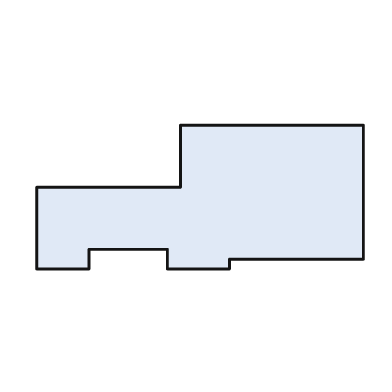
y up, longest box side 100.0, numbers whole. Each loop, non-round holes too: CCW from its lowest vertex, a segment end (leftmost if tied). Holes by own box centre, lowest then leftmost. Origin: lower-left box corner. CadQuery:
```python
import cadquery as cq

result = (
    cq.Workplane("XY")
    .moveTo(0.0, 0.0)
    .lineTo(16.0, 0.0)
    .lineTo(16.0, 6.0)
    .lineTo(40.0, 6.0)
    .lineTo(40.0, 0.0)
    .lineTo(59.0, 0.0)
    .lineTo(59.0, 3.0)
    .lineTo(100.0, 3.0)
    .lineTo(100.0, 44.0)
    .lineTo(44.0, 44.0)
    .lineTo(44.0, 25.0)
    .lineTo(0.0, 25.0)
    .close()
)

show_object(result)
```